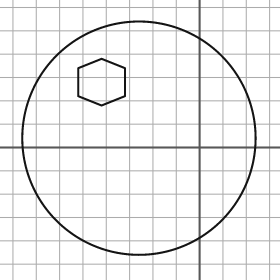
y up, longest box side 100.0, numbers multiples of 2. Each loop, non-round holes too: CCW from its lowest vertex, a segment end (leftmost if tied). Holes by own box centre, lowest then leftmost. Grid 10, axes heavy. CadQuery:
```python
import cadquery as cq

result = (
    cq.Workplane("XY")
    .moveTo(-26.0, 4.0)
    .circle(50.0)
    .moveTo(-42.0, 18.0)
    .lineTo(-32.0, 22.0)
    .lineTo(-32.0, 34.0)
    .lineTo(-42.0, 38.0)
    .lineTo(-52.0, 34.0)
    .lineTo(-52.0, 22.0)
    .close()
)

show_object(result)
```